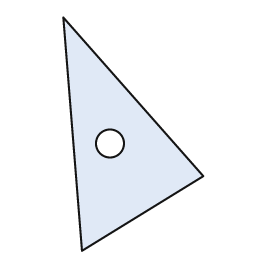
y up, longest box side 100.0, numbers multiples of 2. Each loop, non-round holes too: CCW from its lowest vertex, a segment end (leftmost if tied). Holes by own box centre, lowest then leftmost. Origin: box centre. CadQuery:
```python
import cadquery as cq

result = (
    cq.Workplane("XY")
    .moveTo(-22.0, -50.0)
    .lineTo(30.0, -18.0)
    .lineTo(-30.0, 50.0)
    .close()
    .moveTo(-10.0, -4.0)
    .circle(6.0)
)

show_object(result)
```